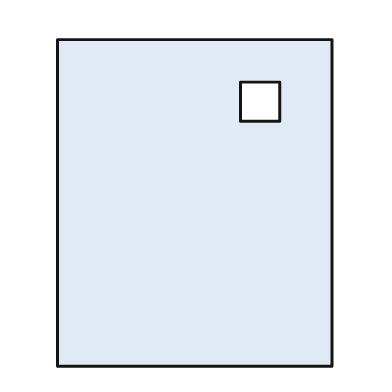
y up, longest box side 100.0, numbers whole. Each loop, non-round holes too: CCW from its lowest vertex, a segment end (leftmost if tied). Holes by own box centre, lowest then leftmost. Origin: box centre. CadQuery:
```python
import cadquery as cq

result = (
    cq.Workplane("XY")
    .moveTo(-42.0, -50.0)
    .lineTo(42.0, -50.0)
    .lineTo(42.0, 50.0)
    .lineTo(-42.0, 50.0)
    .close()
    .moveTo(14.0, 25.0)
    .lineTo(26.0, 25.0)
    .lineTo(26.0, 37.0)
    .lineTo(14.0, 37.0)
    .close()
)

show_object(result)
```